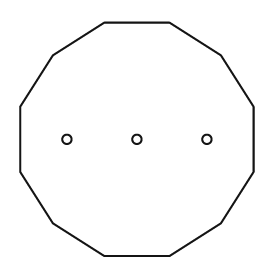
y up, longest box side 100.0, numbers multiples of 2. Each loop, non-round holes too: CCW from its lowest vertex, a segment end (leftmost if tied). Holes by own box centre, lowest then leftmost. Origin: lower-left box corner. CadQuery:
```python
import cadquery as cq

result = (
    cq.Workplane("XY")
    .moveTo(36.0, 0.0)
    .lineTo(64.0, 0.0)
    .lineTo(86.0, 14.0)
    .lineTo(100.0, 36.0)
    .lineTo(100.0, 64.0)
    .lineTo(86.0, 86.0)
    .lineTo(64.0, 100.0)
    .lineTo(36.0, 100.0)
    .lineTo(14.0, 86.0)
    .lineTo(0.0, 64.0)
    .lineTo(0.0, 36.0)
    .lineTo(14.0, 14.0)
    .close()
    .moveTo(20.0, 50.0)
    .circle(2.0)
    .moveTo(50.0, 50.0)
    .circle(2.0)
    .moveTo(80.0, 50.0)
    .circle(2.0)
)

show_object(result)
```